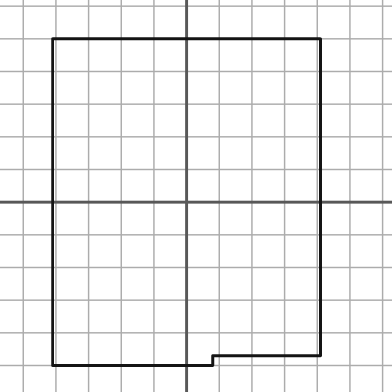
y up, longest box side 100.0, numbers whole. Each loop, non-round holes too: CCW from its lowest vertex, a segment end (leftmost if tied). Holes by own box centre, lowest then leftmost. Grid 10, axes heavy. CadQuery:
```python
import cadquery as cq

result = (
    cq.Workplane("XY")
    .moveTo(-41.0, -50.0)
    .lineTo(8.0, -50.0)
    .lineTo(8.0, -47.0)
    .lineTo(41.0, -47.0)
    .lineTo(41.0, 50.0)
    .lineTo(-41.0, 50.0)
    .close()
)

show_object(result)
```